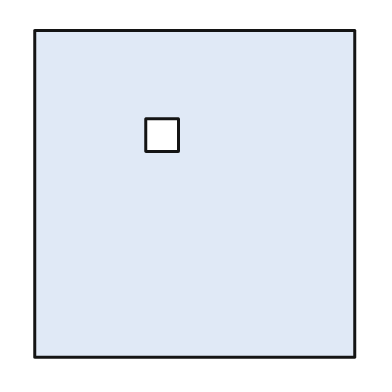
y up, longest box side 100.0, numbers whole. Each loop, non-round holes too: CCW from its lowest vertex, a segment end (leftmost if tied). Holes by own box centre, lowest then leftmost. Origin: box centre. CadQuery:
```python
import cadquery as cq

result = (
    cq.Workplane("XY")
    .moveTo(-49.0, -50.0)
    .lineTo(49.0, -50.0)
    .lineTo(49.0, 50.0)
    .lineTo(-49.0, 50.0)
    .close()
    .moveTo(-15.0, 13.0)
    .lineTo(-5.0, 13.0)
    .lineTo(-5.0, 23.0)
    .lineTo(-15.0, 23.0)
    .close()
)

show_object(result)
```